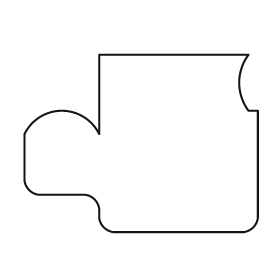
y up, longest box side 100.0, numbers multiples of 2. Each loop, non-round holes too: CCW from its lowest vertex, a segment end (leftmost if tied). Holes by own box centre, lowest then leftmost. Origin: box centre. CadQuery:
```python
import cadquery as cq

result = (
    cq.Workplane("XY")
    .moveTo(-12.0, -38.0)
    .lineTo(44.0, -38.0)
    .threePointArc((48.0, -36.0), (50.0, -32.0))
    .lineTo(50.0, 14.0)
    .lineTo(46.0, 14.0)
    .threePointArc((42.0, 26.0), (46.0, 38.0))
    .lineTo(-18.0, 38.0)
    .lineTo(-18.0, 4.0)
    .threePointArc((-34.0, 14.0), (-50.0, 4.0))
    .lineTo(-50.0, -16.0)
    .threePointArc((-48.0, -20.0), (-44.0, -22.0))
    .lineTo(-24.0, -22.0)
    .threePointArc((-20.0, -24.0), (-18.0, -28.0))
    .lineTo(-18.0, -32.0)
    .threePointArc((-16.0, -36.0), (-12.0, -38.0))
    .close()
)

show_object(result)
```